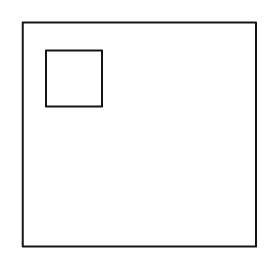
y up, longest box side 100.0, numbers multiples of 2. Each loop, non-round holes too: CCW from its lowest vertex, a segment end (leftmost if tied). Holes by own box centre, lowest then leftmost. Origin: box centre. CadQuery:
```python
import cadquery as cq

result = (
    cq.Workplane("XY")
    .moveTo(-50.0, -48.0)
    .lineTo(50.0, -48.0)
    .lineTo(50.0, 48.0)
    .lineTo(-50.0, 48.0)
    .close()
    .moveTo(-40.0, 12.0)
    .lineTo(-16.0, 12.0)
    .lineTo(-16.0, 36.0)
    .lineTo(-40.0, 36.0)
    .close()
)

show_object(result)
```